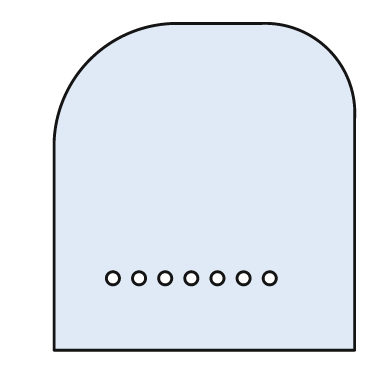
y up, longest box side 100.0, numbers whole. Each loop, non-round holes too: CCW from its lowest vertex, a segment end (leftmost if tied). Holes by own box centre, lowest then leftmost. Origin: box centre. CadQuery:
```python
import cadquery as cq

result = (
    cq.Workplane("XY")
    .moveTo(-46.0, -50.0)
    .lineTo(46.0, -50.0)
    .lineTo(46.0, 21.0)
    .threePointArc((38.0, 42.0), (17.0, 50.0))
    .lineTo(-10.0, 50.0)
    .threePointArc((-35.0, 39.0), (-46.0, 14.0))
    .close()
    .moveTo(-28.0, -28.0)
    .circle(2.0)
    .moveTo(-20.0, -28.0)
    .circle(2.0)
    .moveTo(-12.0, -28.0)
    .circle(2.0)
    .moveTo(-4.0, -28.0)
    .circle(2.0)
    .moveTo(4.0, -28.0)
    .circle(2.0)
    .moveTo(12.0, -28.0)
    .circle(2.0)
    .moveTo(20.0, -28.0)
    .circle(2.0)
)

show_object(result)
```